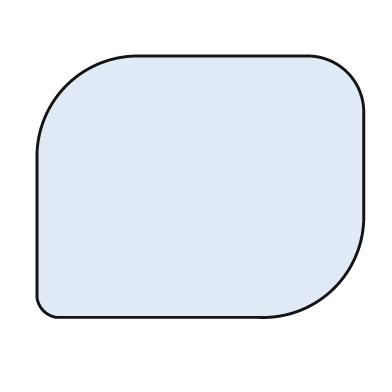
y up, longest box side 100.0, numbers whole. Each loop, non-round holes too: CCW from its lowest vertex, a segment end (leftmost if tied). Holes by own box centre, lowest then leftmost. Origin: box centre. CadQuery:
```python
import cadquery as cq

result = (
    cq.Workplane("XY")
    .moveTo(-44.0, -40.0)
    .lineTo(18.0, -40.0)
    .threePointArc((41.0, -31.0), (50.0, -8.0))
    .lineTo(50.0, 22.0)
    .threePointArc((45.0, 35.0), (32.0, 40.0))
    .lineTo(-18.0, 40.0)
    .threePointArc((-41.0, 31.0), (-50.0, 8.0))
    .lineTo(-50.0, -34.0)
    .threePointArc((-48.0, -38.0), (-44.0, -40.0))
    .close()
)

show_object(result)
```